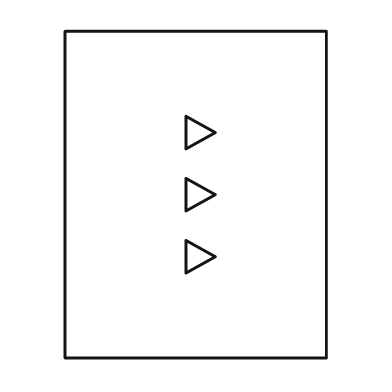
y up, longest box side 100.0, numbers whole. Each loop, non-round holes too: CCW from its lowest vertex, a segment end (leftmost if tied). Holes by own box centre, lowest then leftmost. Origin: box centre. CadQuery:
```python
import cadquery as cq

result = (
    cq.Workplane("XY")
    .moveTo(-40.0, -50.0)
    .lineTo(40.0, -50.0)
    .lineTo(40.0, 50.0)
    .lineTo(-40.0, 50.0)
    .close()
    .moveTo(-3.0, -24.0)
    .lineTo(6.0, -19.0)
    .lineTo(-3.0, -14.0)
    .close()
    .moveTo(-3.0, -5.0)
    .lineTo(6.0, 0.0)
    .lineTo(-3.0, 5.0)
    .close()
    .moveTo(-3.0, 14.0)
    .lineTo(6.0, 19.0)
    .lineTo(-3.0, 24.0)
    .close()
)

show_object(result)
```